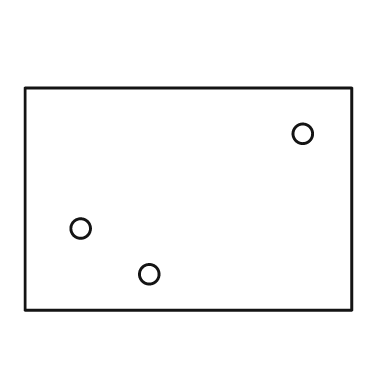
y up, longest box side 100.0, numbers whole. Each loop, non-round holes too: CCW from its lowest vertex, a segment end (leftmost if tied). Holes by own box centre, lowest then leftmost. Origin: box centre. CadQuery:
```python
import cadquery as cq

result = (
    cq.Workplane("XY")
    .moveTo(-50.0, -34.0)
    .lineTo(50.0, -34.0)
    .lineTo(50.0, 34.0)
    .lineTo(-50.0, 34.0)
    .close()
    .moveTo(-12.0, -23.0)
    .circle(3.0)
    .moveTo(-33.0, -9.0)
    .circle(3.0)
    .moveTo(35.0, 20.0)
    .circle(3.0)
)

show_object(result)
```